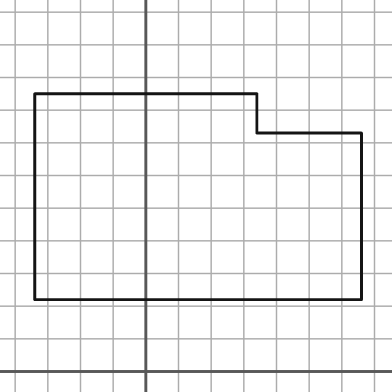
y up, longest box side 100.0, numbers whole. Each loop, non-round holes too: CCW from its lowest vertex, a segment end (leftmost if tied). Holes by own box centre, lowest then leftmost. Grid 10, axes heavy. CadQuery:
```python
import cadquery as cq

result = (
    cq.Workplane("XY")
    .moveTo(-34.0, 22.0)
    .lineTo(66.0, 22.0)
    .lineTo(66.0, 73.0)
    .lineTo(34.0, 73.0)
    .lineTo(34.0, 85.0)
    .lineTo(-34.0, 85.0)
    .close()
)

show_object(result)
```